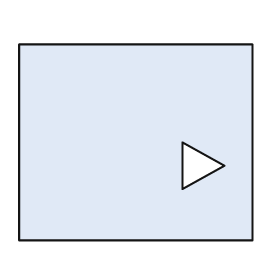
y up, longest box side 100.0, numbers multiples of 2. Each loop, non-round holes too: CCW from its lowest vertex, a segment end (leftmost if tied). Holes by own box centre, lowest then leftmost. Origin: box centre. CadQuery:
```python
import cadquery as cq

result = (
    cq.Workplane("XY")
    .moveTo(-50.0, -42.0)
    .lineTo(50.0, -42.0)
    .lineTo(50.0, 42.0)
    .lineTo(-50.0, 42.0)
    .close()
    .moveTo(20.0, -20.0)
    .lineTo(38.0, -10.0)
    .lineTo(20.0, 0.0)
    .close()
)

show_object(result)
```